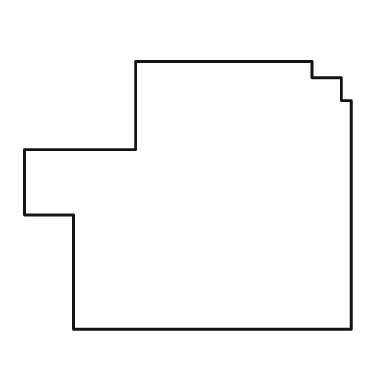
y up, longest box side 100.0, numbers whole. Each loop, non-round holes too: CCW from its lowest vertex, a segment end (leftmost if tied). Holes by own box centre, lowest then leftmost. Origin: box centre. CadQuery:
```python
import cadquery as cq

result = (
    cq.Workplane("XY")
    .moveTo(-35.0, -41.0)
    .lineTo(50.0, -41.0)
    .lineTo(50.0, 29.0)
    .lineTo(47.0, 29.0)
    .lineTo(47.0, 36.0)
    .lineTo(38.0, 36.0)
    .lineTo(38.0, 41.0)
    .lineTo(-16.0, 41.0)
    .lineTo(-16.0, 14.0)
    .lineTo(-50.0, 14.0)
    .lineTo(-50.0, -6.0)
    .lineTo(-35.0, -6.0)
    .close()
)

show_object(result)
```